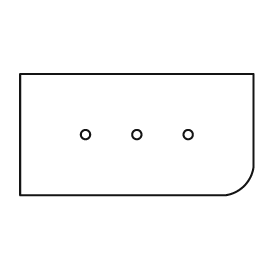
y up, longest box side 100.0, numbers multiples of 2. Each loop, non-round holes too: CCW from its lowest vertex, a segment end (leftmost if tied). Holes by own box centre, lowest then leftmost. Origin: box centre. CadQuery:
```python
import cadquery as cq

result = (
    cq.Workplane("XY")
    .moveTo(-50.0, -26.0)
    .lineTo(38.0, -26.0)
    .threePointArc((46.0, -22.0), (50.0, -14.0))
    .lineTo(50.0, 26.0)
    .lineTo(-50.0, 26.0)
    .close()
    .moveTo(-22.0, 0.0)
    .circle(2.0)
    .moveTo(0.0, 0.0)
    .circle(2.0)
    .moveTo(22.0, 0.0)
    .circle(2.0)
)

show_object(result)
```